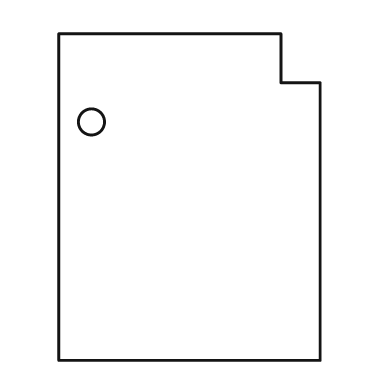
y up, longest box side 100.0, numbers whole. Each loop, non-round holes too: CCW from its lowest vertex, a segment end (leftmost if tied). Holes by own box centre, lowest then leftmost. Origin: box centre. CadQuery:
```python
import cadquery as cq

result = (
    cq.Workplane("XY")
    .moveTo(-40.0, -50.0)
    .lineTo(40.0, -50.0)
    .lineTo(40.0, 35.0)
    .lineTo(28.0, 35.0)
    .lineTo(28.0, 50.0)
    .lineTo(-40.0, 50.0)
    .close()
    .moveTo(-30.0, 23.0)
    .circle(4.0)
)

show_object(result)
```